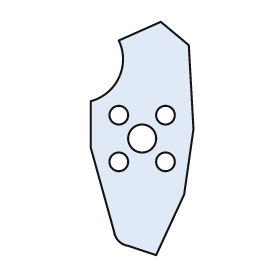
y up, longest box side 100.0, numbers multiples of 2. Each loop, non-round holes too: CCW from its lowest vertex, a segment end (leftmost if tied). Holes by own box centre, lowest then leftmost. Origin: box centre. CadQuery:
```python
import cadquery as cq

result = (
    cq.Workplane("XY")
    .moveTo(6.0, -50.0)
    .lineTo(18.0, -24.0)
    .lineTo(22.0, 4.0)
    .lineTo(20.0, 40.0)
    .lineTo(8.0, 50.0)
    .lineTo(-10.0, 42.0)
    .threePointArc((-10.0, 26.0), (-22.0, 16.0))
    .lineTo(-22.0, -4.0)
    .lineTo(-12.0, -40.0)
    .threePointArc((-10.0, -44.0), (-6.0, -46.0))
    .close()
    .moveTo(-10.0, -10.0)
    .circle(4.0)
    .moveTo(10.0, -10.0)
    .circle(4.0)
    .moveTo(0.0, 0.0)
    .circle(6.0)
    .moveTo(-10.0, 10.0)
    .circle(4.0)
    .moveTo(10.0, 10.0)
    .circle(4.0)
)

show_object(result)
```